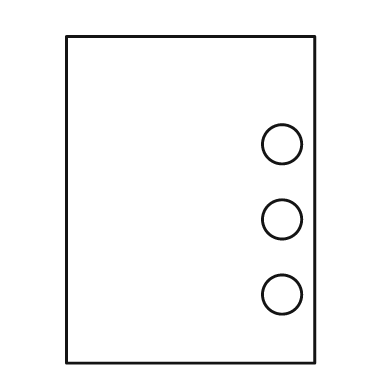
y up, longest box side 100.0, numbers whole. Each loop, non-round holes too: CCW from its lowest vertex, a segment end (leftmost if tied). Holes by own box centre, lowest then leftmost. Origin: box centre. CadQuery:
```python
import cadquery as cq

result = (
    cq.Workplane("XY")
    .moveTo(-38.0, -50.0)
    .lineTo(38.0, -50.0)
    .lineTo(38.0, 50.0)
    .lineTo(-38.0, 50.0)
    .close()
    .moveTo(28.0, -29.0)
    .circle(6.0)
    .moveTo(28.0, -6.0)
    .circle(6.0)
    .moveTo(28.0, 17.0)
    .circle(6.0)
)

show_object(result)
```